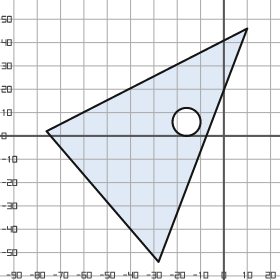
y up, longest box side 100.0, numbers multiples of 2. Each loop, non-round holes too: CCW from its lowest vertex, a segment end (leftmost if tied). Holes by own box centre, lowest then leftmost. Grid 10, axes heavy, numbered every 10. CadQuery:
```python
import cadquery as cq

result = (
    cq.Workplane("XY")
    .moveTo(-28.0, -54.0)
    .lineTo(10.0, 46.0)
    .lineTo(-76.0, 2.0)
    .close()
    .moveTo(-16.0, 6.0)
    .circle(6.0)
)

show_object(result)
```